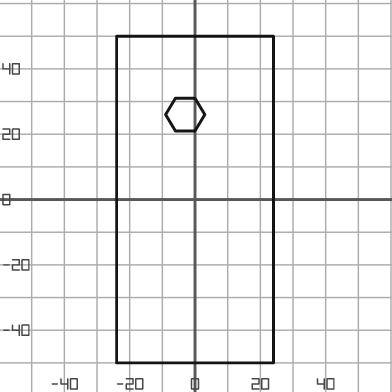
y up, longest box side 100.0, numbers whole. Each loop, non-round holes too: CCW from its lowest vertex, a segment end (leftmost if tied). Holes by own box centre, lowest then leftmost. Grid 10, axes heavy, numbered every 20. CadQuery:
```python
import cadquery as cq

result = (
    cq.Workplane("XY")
    .moveTo(-24.0, -50.0)
    .lineTo(24.0, -50.0)
    .lineTo(24.0, 50.0)
    .lineTo(-24.0, 50.0)
    .close()
    .moveTo(-6.0, 21.0)
    .lineTo(0.0, 21.0)
    .lineTo(3.0, 26.0)
    .lineTo(0.0, 31.0)
    .lineTo(-6.0, 31.0)
    .lineTo(-9.0, 26.0)
    .close()
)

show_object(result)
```